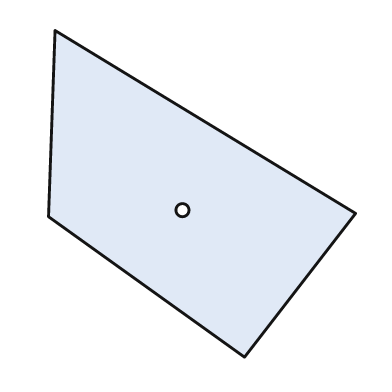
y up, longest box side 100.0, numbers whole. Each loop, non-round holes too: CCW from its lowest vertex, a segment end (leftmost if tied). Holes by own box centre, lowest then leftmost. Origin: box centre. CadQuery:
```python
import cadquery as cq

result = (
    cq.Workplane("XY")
    .moveTo(13.0, -50.0)
    .lineTo(47.0, -6.0)
    .lineTo(-45.0, 50.0)
    .lineTo(-47.0, -7.0)
    .close()
    .moveTo(-6.0, -5.0)
    .circle(2.0)
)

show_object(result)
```